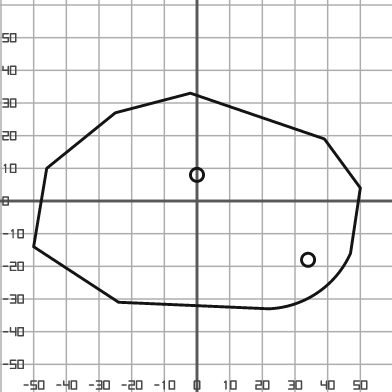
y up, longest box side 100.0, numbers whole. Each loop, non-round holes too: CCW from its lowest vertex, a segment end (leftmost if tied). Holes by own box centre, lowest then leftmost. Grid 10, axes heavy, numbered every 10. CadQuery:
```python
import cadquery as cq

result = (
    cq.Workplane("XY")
    .moveTo(22.0, -33.0)
    .threePointArc((37.0, -28.0), (47.0, -16.0))
    .lineTo(50.0, 4.0)
    .lineTo(39.0, 19.0)
    .lineTo(-2.0, 33.0)
    .lineTo(-25.0, 27.0)
    .lineTo(-46.0, 10.0)
    .lineTo(-50.0, -14.0)
    .lineTo(-24.0, -31.0)
    .close()
    .moveTo(34.0, -18.0)
    .circle(2.0)
    .moveTo(0.0, 8.0)
    .circle(2.0)
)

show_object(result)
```